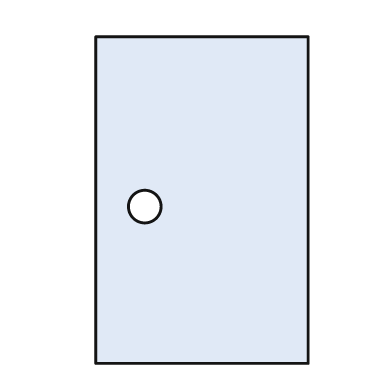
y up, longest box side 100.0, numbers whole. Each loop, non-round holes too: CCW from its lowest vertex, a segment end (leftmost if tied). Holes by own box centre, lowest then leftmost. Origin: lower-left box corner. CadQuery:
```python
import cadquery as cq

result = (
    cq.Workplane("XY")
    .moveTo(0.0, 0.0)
    .lineTo(65.0, 0.0)
    .lineTo(65.0, 100.0)
    .lineTo(0.0, 100.0)
    .close()
    .moveTo(15.0, 48.0)
    .circle(5.0)
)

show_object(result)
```